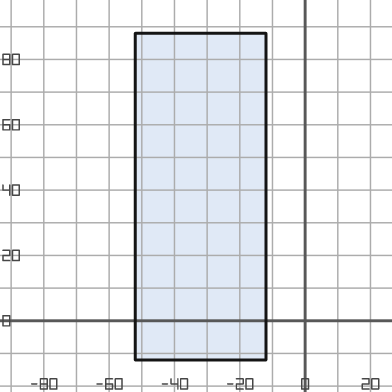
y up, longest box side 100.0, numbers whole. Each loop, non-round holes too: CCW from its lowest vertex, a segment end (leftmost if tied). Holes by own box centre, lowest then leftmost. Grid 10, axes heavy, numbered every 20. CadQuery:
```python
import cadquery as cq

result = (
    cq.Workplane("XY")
    .moveTo(-52.0, -12.0)
    .lineTo(-12.0, -12.0)
    .lineTo(-12.0, 88.0)
    .lineTo(-52.0, 88.0)
    .close()
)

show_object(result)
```